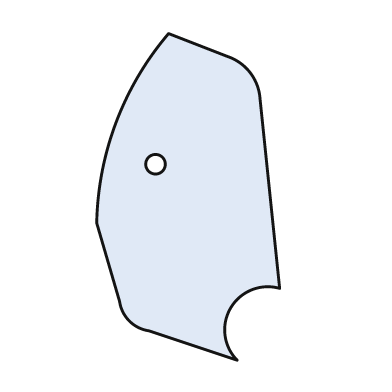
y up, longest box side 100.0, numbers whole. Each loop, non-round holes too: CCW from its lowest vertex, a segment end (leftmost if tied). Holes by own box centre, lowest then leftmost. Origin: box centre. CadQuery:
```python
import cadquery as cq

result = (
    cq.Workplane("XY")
    .moveTo(15.0, -50.0)
    .threePointArc((13.0, -34.0), (28.0, -28.0))
    .lineTo(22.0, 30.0)
    .threePointArc((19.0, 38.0), (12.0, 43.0))
    .lineTo(-6.0, 50.0)
    .threePointArc((-22.0, 23.0), (-28.0, -8.0))
    .lineTo(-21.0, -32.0)
    .threePointArc((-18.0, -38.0), (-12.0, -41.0))
    .close()
    .moveTo(-10.0, 10.0)
    .circle(3.0)
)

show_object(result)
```